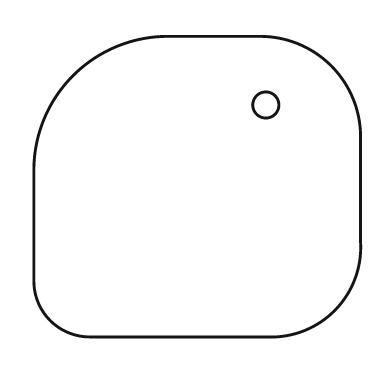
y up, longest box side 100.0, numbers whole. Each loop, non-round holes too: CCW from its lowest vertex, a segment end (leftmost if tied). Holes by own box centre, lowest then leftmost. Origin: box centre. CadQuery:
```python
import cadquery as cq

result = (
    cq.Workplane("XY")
    .moveTo(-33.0, -46.0)
    .lineTo(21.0, -46.0)
    .threePointArc((42.0, -38.0), (50.0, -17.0))
    .lineTo(50.0, 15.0)
    .threePointArc((41.0, 37.0), (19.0, 46.0))
    .lineTo(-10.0, 46.0)
    .threePointArc((-38.0, 34.0), (-50.0, 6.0))
    .lineTo(-50.0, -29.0)
    .threePointArc((-45.0, -41.0), (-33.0, -46.0))
    .close()
    .moveTo(21.0, 25.0)
    .circle(4.0)
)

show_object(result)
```